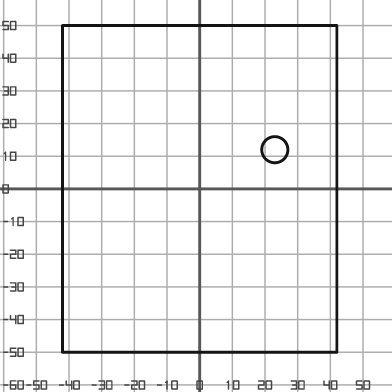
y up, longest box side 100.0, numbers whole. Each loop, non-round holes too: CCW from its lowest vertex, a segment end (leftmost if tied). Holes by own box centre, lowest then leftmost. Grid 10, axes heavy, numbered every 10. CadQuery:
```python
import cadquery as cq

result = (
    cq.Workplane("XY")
    .moveTo(-42.0, -50.0)
    .lineTo(42.0, -50.0)
    .lineTo(42.0, 50.0)
    .lineTo(-42.0, 50.0)
    .close()
    .moveTo(23.0, 12.0)
    .circle(4.0)
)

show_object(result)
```